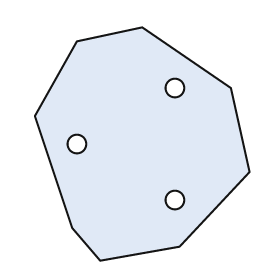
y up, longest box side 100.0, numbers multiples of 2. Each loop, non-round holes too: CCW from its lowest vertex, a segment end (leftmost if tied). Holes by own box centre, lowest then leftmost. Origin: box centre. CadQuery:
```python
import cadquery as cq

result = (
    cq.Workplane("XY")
    .moveTo(-18.0, -50.0)
    .lineTo(16.0, -44.0)
    .lineTo(46.0, -12.0)
    .lineTo(38.0, 24.0)
    .lineTo(0.0, 50.0)
    .lineTo(-28.0, 44.0)
    .lineTo(-46.0, 12.0)
    .lineTo(-30.0, -36.0)
    .close()
    .moveTo(14.0, -24.0)
    .circle(4.0)
    .moveTo(-28.0, 0.0)
    .circle(4.0)
    .moveTo(14.0, 24.0)
    .circle(4.0)
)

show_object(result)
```